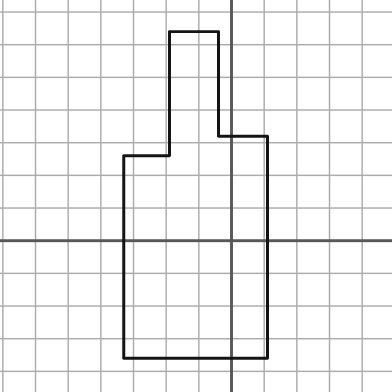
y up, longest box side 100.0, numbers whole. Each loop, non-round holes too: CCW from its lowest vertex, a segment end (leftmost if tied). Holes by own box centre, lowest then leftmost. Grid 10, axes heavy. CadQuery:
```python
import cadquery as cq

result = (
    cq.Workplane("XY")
    .moveTo(-33.0, -36.0)
    .lineTo(11.0, -36.0)
    .lineTo(11.0, 32.0)
    .lineTo(-4.0, 32.0)
    .lineTo(-4.0, 64.0)
    .lineTo(-19.0, 64.0)
    .lineTo(-19.0, 26.0)
    .lineTo(-33.0, 26.0)
    .close()
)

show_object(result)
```